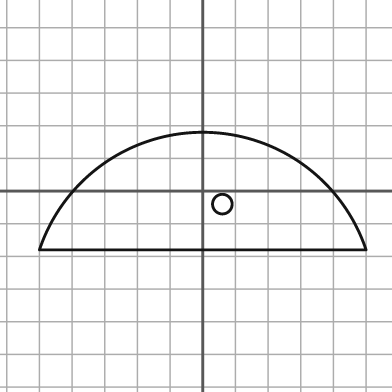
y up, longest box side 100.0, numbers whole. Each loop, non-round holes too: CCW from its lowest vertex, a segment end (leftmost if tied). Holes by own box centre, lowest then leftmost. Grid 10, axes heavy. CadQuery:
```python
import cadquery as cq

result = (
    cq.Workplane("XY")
    .moveTo(-50.0, -18.0)
    .lineTo(50.0, -18.0)
    .threePointArc((0.0, 18.0), (-50.0, -18.0))
    .close()
    .moveTo(6.0, -4.0)
    .circle(3.0)
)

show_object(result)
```